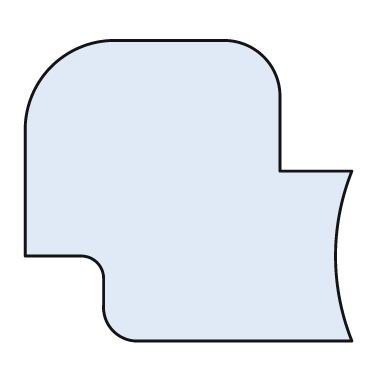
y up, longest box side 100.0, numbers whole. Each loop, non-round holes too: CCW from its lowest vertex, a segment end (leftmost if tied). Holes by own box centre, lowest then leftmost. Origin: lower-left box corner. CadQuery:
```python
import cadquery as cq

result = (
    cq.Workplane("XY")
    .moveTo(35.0, 0.0)
    .lineTo(100.0, 0.0)
    .threePointArc((95.0, 26.0), (100.0, 52.0))
    .lineTo(78.0, 52.0)
    .lineTo(78.0, 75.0)
    .threePointArc((73.0, 87.0), (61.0, 92.0))
    .lineTo(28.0, 92.0)
    .threePointArc((8.0, 84.0), (0.0, 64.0))
    .lineTo(0.0, 26.0)
    .lineTo(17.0, 26.0)
    .threePointArc((22.0, 24.0), (24.0, 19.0))
    .lineTo(24.0, 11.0)
    .threePointArc((27.0, 3.0), (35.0, 0.0))
    .close()
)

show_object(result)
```